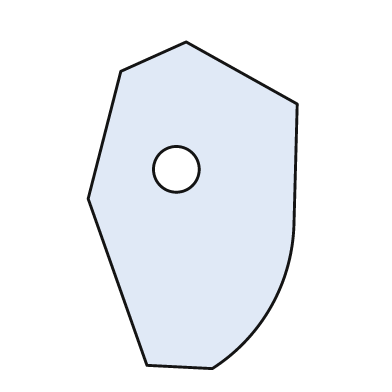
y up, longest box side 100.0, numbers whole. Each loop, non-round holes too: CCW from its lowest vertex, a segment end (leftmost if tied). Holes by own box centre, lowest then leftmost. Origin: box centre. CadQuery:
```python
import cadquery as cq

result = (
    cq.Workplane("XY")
    .moveTo(6.0, -50.0)
    .threePointArc((24.0, -31.0), (31.0, -6.0))
    .lineTo(32.0, 31.0)
    .lineTo(-2.0, 50.0)
    .lineTo(-22.0, 41.0)
    .lineTo(-32.0, 2.0)
    .lineTo(-14.0, -49.0)
    .close()
    .moveTo(-5.0, 11.0)
    .circle(7.0)
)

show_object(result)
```